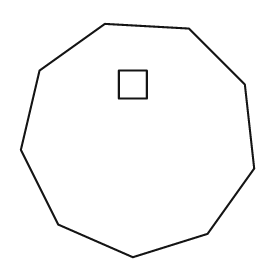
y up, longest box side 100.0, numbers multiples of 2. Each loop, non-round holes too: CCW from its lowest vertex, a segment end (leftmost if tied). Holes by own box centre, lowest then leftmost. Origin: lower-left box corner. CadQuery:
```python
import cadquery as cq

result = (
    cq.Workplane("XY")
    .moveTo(48.0, 0.0)
    .lineTo(80.0, 10.0)
    .lineTo(100.0, 38.0)
    .lineTo(96.0, 74.0)
    .lineTo(72.0, 98.0)
    .lineTo(36.0, 100.0)
    .lineTo(8.0, 80.0)
    .lineTo(0.0, 46.0)
    .lineTo(16.0, 14.0)
    .close()
    .moveTo(42.0, 68.0)
    .lineTo(54.0, 68.0)
    .lineTo(54.0, 80.0)
    .lineTo(42.0, 80.0)
    .close()
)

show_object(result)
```